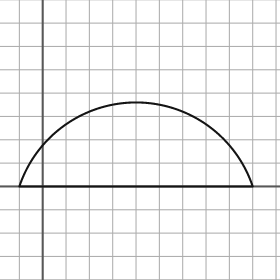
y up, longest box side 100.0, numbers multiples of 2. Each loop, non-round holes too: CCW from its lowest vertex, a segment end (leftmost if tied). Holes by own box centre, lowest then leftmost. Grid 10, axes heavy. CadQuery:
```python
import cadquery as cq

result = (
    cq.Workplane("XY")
    .moveTo(-10.0, 0.0)
    .lineTo(90.0, 0.0)
    .threePointArc((40.0, 36.0), (-10.0, 0.0))
    .close()
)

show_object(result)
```